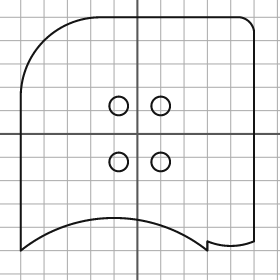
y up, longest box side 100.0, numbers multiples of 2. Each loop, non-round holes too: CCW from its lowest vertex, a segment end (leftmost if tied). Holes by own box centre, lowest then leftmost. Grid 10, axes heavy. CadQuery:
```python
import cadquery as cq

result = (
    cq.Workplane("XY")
    .moveTo(-50.0, -50.0)
    .threePointArc((-10.0, -36.0), (30.0, -50.0))
    .lineTo(30.0, -46.0)
    .threePointArc((40.0, -48.0), (50.0, -46.0))
    .lineTo(50.0, 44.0)
    .threePointArc((48.0, 48.0), (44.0, 50.0))
    .lineTo(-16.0, 50.0)
    .threePointArc((-40.0, 40.0), (-50.0, 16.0))
    .close()
    .moveTo(-8.0, -12.0)
    .circle(4.0)
    .moveTo(10.0, -12.0)
    .circle(4.0)
    .moveTo(-8.0, 12.0)
    .circle(4.0)
    .moveTo(10.0, 12.0)
    .circle(4.0)
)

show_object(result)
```